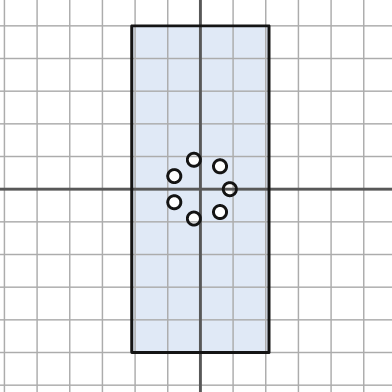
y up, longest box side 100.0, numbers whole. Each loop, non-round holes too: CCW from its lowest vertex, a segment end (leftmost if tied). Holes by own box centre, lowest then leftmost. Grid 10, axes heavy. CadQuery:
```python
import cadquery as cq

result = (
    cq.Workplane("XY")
    .moveTo(-21.0, -50.0)
    .lineTo(21.0, -50.0)
    .lineTo(21.0, 50.0)
    .lineTo(-21.0, 50.0)
    .close()
    .moveTo(-2.0, -9.0)
    .circle(2.0)
    .moveTo(6.0, -7.0)
    .circle(2.0)
    .moveTo(-8.0, -4.0)
    .circle(2.0)
    .moveTo(9.0, 0.0)
    .circle(2.0)
    .moveTo(-8.0, 4.0)
    .circle(2.0)
    .moveTo(6.0, 7.0)
    .circle(2.0)
    .moveTo(-2.0, 9.0)
    .circle(2.0)
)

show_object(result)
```